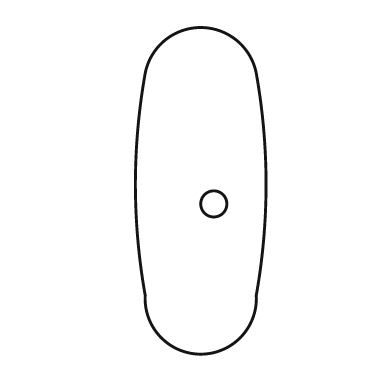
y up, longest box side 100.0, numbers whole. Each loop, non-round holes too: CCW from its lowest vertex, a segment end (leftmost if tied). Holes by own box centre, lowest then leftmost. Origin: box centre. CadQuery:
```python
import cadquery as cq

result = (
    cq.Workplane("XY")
    .moveTo(-17.0, -32.0)
    .threePointArc((0.0, -50.0), (17.0, -32.0))
    .threePointArc((20.0, 2.0), (17.0, 36.0))
    .threePointArc((0.0, 50.0), (-17.0, 36.0))
    .threePointArc((-20.0, 2.0), (-17.0, -32.0))
    .close()
    .moveTo(4.0, -4.0)
    .circle(4.0)
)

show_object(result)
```